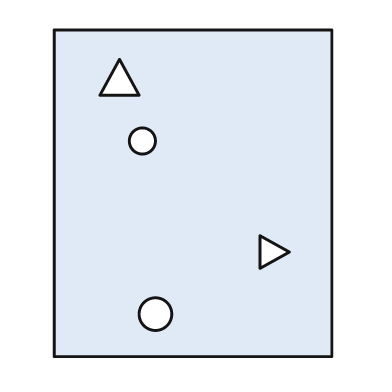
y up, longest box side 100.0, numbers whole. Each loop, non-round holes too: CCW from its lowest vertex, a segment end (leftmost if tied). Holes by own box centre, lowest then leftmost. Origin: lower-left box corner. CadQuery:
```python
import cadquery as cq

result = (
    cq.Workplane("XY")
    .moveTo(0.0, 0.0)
    .lineTo(85.0, 0.0)
    .lineTo(85.0, 100.0)
    .lineTo(0.0, 100.0)
    .close()
    .moveTo(31.0, 13.0)
    .circle(5.0)
    .moveTo(63.0, 27.0)
    .lineTo(72.0, 32.0)
    .lineTo(63.0, 37.0)
    .close()
    .moveTo(27.0, 66.0)
    .circle(4.0)
    .moveTo(14.0, 80.0)
    .lineTo(26.0, 80.0)
    .lineTo(20.0, 91.0)
    .close()
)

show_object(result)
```